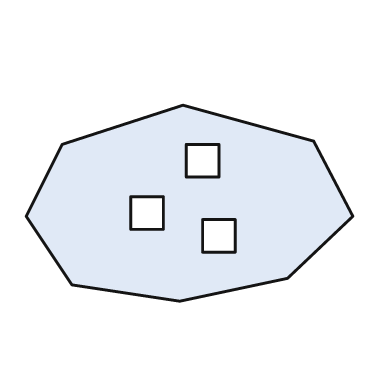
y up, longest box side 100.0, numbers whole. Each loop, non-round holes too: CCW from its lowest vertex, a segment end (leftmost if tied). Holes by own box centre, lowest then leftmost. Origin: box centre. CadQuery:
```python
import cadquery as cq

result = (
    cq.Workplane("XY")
    .moveTo(-3.0, -30.0)
    .lineTo(30.0, -23.0)
    .lineTo(50.0, -4.0)
    .lineTo(38.0, 19.0)
    .lineTo(-2.0, 30.0)
    .lineTo(-39.0, 18.0)
    .lineTo(-50.0, -4.0)
    .lineTo(-36.0, -25.0)
    .close()
    .moveTo(4.0, -15.0)
    .lineTo(14.0, -15.0)
    .lineTo(14.0, -5.0)
    .lineTo(4.0, -5.0)
    .close()
    .moveTo(-18.0, -8.0)
    .lineTo(-8.0, -8.0)
    .lineTo(-8.0, 2.0)
    .lineTo(-18.0, 2.0)
    .close()
    .moveTo(-1.0, 8.0)
    .lineTo(9.0, 8.0)
    .lineTo(9.0, 18.0)
    .lineTo(-1.0, 18.0)
    .close()
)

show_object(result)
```